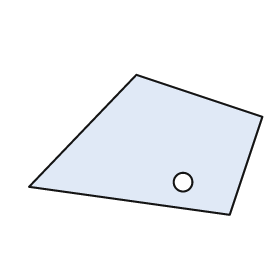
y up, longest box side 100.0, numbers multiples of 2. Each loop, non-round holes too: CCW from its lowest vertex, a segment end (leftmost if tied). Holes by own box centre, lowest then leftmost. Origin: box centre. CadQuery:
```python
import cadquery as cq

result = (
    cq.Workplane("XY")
    .moveTo(36.0, -30.0)
    .lineTo(50.0, 12.0)
    .lineTo(-4.0, 30.0)
    .lineTo(-50.0, -18.0)
    .close()
    .moveTo(16.0, -16.0)
    .circle(4.0)
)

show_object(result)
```